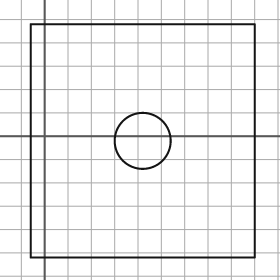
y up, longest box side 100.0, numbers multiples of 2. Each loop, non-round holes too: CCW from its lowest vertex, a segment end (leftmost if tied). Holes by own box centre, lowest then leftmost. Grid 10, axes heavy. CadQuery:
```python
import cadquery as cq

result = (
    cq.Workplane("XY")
    .moveTo(-6.0, -52.0)
    .lineTo(90.0, -52.0)
    .lineTo(90.0, 48.0)
    .lineTo(-6.0, 48.0)
    .close()
    .moveTo(42.0, -2.0)
    .circle(12.0)
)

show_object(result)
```